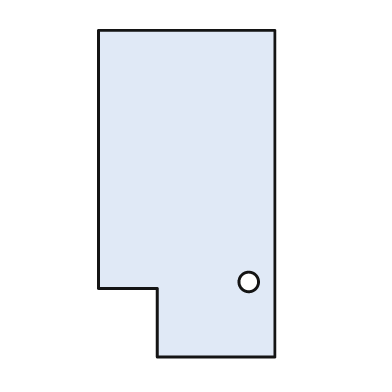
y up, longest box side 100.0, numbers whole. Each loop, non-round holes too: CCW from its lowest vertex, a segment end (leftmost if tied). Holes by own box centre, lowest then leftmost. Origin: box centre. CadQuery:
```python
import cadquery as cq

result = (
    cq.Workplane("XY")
    .moveTo(-9.0, -50.0)
    .lineTo(27.0, -50.0)
    .lineTo(27.0, 50.0)
    .lineTo(-27.0, 50.0)
    .lineTo(-27.0, -29.0)
    .lineTo(-9.0, -29.0)
    .close()
    .moveTo(19.0, -27.0)
    .circle(3.0)
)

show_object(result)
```